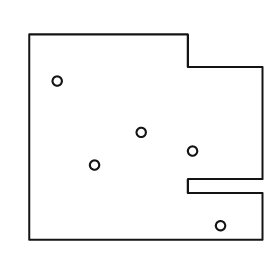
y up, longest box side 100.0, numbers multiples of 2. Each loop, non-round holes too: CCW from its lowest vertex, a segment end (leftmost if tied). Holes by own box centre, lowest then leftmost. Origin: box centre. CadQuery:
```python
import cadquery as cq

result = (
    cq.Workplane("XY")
    .moveTo(-50.0, -44.0)
    .lineTo(50.0, -44.0)
    .lineTo(50.0, -24.0)
    .lineTo(18.0, -24.0)
    .lineTo(18.0, -18.0)
    .lineTo(50.0, -18.0)
    .lineTo(50.0, 30.0)
    .lineTo(18.0, 30.0)
    .lineTo(18.0, 44.0)
    .lineTo(-50.0, 44.0)
    .close()
    .moveTo(32.0, -38.0)
    .circle(2.0)
    .moveTo(-22.0, -12.0)
    .circle(2.0)
    .moveTo(20.0, -6.0)
    .circle(2.0)
    .moveTo(-2.0, 2.0)
    .circle(2.0)
    .moveTo(-38.0, 24.0)
    .circle(2.0)
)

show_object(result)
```